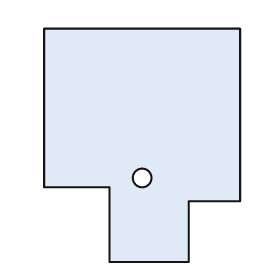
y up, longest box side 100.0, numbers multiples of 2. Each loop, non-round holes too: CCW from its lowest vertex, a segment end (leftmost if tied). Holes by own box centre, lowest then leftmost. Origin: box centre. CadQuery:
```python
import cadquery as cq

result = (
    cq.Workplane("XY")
    .moveTo(-14.0, -50.0)
    .lineTo(20.0, -50.0)
    .lineTo(20.0, -24.0)
    .lineTo(42.0, -24.0)
    .lineTo(42.0, 50.0)
    .lineTo(-42.0, 50.0)
    .lineTo(-42.0, -18.0)
    .lineTo(-14.0, -18.0)
    .close()
    .moveTo(0.0, -14.0)
    .circle(4.0)
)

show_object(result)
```